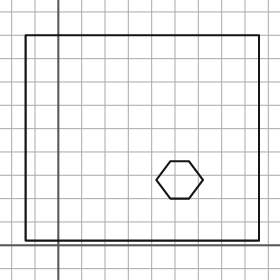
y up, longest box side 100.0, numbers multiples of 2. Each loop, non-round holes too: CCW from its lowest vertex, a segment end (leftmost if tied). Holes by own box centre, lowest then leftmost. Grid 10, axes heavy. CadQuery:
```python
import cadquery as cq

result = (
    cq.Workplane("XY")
    .moveTo(-14.0, 2.0)
    .lineTo(86.0, 2.0)
    .lineTo(86.0, 90.0)
    .lineTo(-14.0, 90.0)
    .close()
    .moveTo(48.0, 20.0)
    .lineTo(56.0, 20.0)
    .lineTo(62.0, 28.0)
    .lineTo(56.0, 36.0)
    .lineTo(48.0, 36.0)
    .lineTo(42.0, 28.0)
    .close()
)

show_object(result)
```